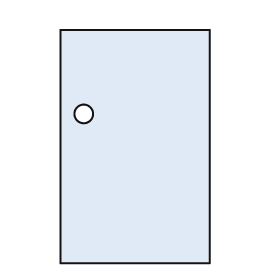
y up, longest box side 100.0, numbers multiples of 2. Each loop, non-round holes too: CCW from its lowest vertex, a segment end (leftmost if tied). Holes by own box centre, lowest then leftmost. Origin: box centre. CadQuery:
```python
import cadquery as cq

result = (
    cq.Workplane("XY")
    .moveTo(-32.0, -50.0)
    .lineTo(32.0, -50.0)
    .lineTo(32.0, 50.0)
    .lineTo(-32.0, 50.0)
    .close()
    .moveTo(-22.0, 14.0)
    .circle(4.0)
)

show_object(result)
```